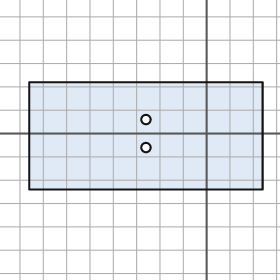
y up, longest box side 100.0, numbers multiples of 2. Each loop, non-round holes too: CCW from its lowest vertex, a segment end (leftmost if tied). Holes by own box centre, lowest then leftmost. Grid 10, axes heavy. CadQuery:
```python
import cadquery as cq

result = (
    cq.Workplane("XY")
    .moveTo(-76.0, -24.0)
    .lineTo(24.0, -24.0)
    .lineTo(24.0, 22.0)
    .lineTo(-76.0, 22.0)
    .close()
    .moveTo(-26.0, -6.0)
    .circle(2.0)
    .moveTo(-26.0, 6.0)
    .circle(2.0)
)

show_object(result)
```